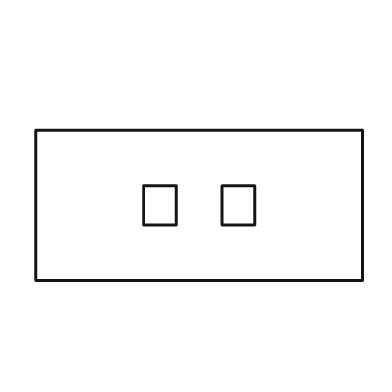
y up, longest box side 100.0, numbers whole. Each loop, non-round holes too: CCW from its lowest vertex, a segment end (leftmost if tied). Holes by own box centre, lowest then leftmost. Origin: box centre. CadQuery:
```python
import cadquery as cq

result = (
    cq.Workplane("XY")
    .moveTo(-50.0, -23.0)
    .lineTo(50.0, -23.0)
    .lineTo(50.0, 23.0)
    .lineTo(-50.0, 23.0)
    .close()
    .moveTo(-17.0, -6.0)
    .lineTo(-7.0, -6.0)
    .lineTo(-7.0, 6.0)
    .lineTo(-17.0, 6.0)
    .close()
    .moveTo(7.0, -6.0)
    .lineTo(17.0, -6.0)
    .lineTo(17.0, 6.0)
    .lineTo(7.0, 6.0)
    .close()
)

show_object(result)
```